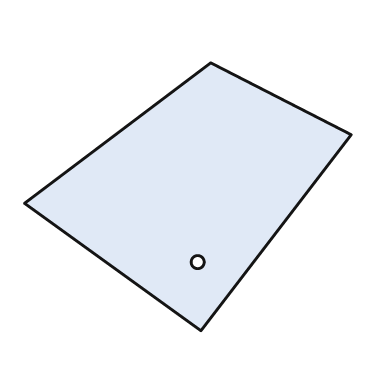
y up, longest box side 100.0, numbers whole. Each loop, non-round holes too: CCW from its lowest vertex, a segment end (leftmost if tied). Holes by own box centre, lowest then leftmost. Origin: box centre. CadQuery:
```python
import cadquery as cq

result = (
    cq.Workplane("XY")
    .moveTo(4.0, -41.0)
    .lineTo(50.0, 19.0)
    .lineTo(7.0, 41.0)
    .lineTo(-50.0, -2.0)
    .close()
    .moveTo(3.0, -20.0)
    .circle(2.0)
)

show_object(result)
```